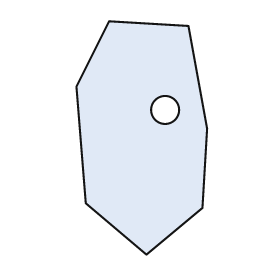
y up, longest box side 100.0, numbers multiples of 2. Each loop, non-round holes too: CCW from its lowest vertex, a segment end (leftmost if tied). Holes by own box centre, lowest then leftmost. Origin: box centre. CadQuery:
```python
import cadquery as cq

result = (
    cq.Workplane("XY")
    .moveTo(2.0, -50.0)
    .lineTo(26.0, -30.0)
    .lineTo(28.0, 4.0)
    .lineTo(20.0, 48.0)
    .lineTo(-14.0, 50.0)
    .lineTo(-28.0, 22.0)
    .lineTo(-24.0, -28.0)
    .close()
    .moveTo(10.0, 12.0)
    .circle(6.0)
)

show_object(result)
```